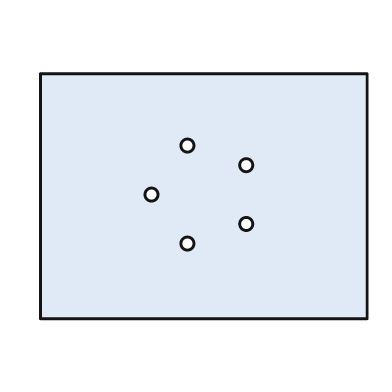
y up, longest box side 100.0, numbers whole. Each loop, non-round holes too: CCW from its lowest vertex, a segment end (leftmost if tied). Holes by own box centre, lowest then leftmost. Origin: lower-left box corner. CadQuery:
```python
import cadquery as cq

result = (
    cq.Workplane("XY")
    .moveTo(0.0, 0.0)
    .lineTo(100.0, 0.0)
    .lineTo(100.0, 75.0)
    .lineTo(0.0, 75.0)
    .close()
    .moveTo(45.0, 23.0)
    .circle(2.0)
    .moveTo(63.0, 29.0)
    .circle(2.0)
    .moveTo(34.0, 38.0)
    .circle(2.0)
    .moveTo(63.0, 47.0)
    .circle(2.0)
    .moveTo(45.0, 53.0)
    .circle(2.0)
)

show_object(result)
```